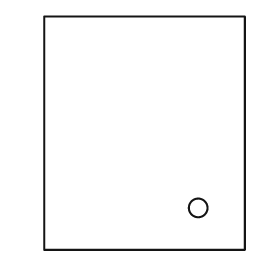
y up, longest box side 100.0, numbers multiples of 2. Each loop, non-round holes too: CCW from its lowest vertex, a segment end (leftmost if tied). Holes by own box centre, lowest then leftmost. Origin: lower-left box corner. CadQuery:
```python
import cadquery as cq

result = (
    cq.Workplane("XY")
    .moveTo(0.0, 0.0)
    .lineTo(86.0, 0.0)
    .lineTo(86.0, 100.0)
    .lineTo(0.0, 100.0)
    .close()
    .moveTo(66.0, 18.0)
    .circle(4.0)
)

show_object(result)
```